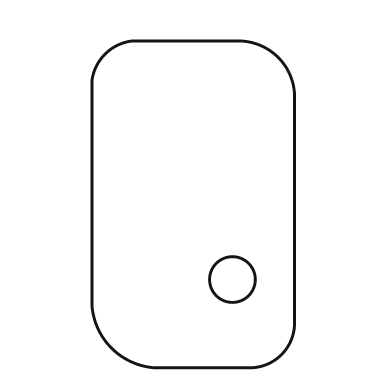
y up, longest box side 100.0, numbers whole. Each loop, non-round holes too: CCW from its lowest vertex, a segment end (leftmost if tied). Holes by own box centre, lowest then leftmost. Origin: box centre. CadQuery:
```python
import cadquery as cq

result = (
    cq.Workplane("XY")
    .moveTo(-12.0, -50.0)
    .lineTo(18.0, -50.0)
    .threePointArc((27.0, -46.0), (31.0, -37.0))
    .lineTo(31.0, 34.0)
    .threePointArc((26.0, 45.0), (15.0, 50.0))
    .lineTo(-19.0, 50.0)
    .threePointArc((-27.0, 46.0), (-31.0, 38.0))
    .lineTo(-31.0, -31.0)
    .threePointArc((-25.0, -44.0), (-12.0, -50.0))
    .close()
    .moveTo(12.0, -23.0)
    .circle(7.0)
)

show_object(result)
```